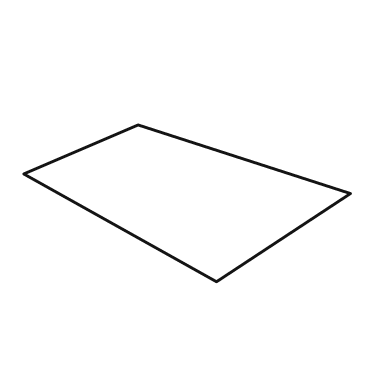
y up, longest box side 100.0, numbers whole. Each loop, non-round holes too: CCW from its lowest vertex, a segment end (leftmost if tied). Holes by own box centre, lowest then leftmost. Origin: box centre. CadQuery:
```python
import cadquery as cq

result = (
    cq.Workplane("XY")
    .moveTo(9.0, -24.0)
    .lineTo(50.0, 3.0)
    .lineTo(-15.0, 24.0)
    .lineTo(-50.0, 9.0)
    .close()
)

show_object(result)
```